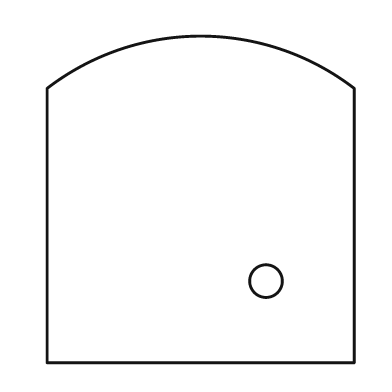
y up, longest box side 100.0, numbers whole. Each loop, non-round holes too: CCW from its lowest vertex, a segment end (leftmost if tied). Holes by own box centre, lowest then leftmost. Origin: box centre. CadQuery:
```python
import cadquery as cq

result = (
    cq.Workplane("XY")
    .moveTo(-47.0, -50.0)
    .lineTo(47.0, -50.0)
    .lineTo(47.0, 34.0)
    .threePointArc((0.0, 50.0), (-47.0, 34.0))
    .close()
    .moveTo(20.0, -25.0)
    .circle(5.0)
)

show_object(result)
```